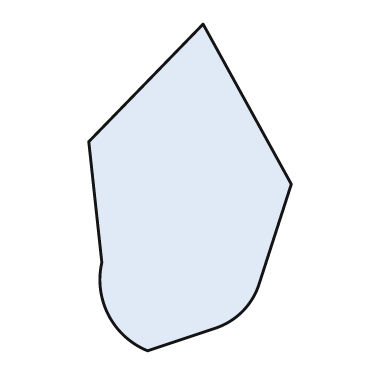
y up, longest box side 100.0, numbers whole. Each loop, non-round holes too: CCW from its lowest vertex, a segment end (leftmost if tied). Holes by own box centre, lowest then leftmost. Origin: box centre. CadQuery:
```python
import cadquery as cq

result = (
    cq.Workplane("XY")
    .moveTo(-13.0, -50.0)
    .lineTo(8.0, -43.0)
    .threePointArc((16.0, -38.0), (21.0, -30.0))
    .lineTo(31.0, 1.0)
    .lineTo(4.0, 50.0)
    .lineTo(-31.0, 14.0)
    .lineTo(-27.0, -23.0)
    .threePointArc((-25.0, -39.0), (-13.0, -50.0))
    .close()
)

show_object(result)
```